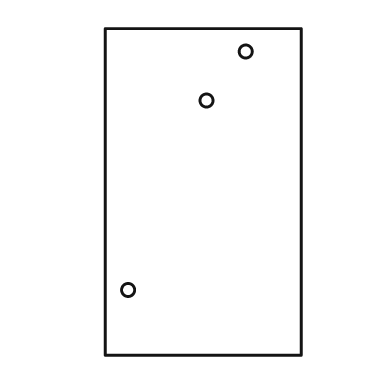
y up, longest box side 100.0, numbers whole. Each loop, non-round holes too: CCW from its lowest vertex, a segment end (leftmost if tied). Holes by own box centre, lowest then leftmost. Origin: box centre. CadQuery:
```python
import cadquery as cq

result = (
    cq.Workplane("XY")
    .moveTo(-30.0, -50.0)
    .lineTo(30.0, -50.0)
    .lineTo(30.0, 50.0)
    .lineTo(-30.0, 50.0)
    .close()
    .moveTo(-23.0, -30.0)
    .circle(2.0)
    .moveTo(1.0, 28.0)
    .circle(2.0)
    .moveTo(13.0, 43.0)
    .circle(2.0)
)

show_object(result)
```